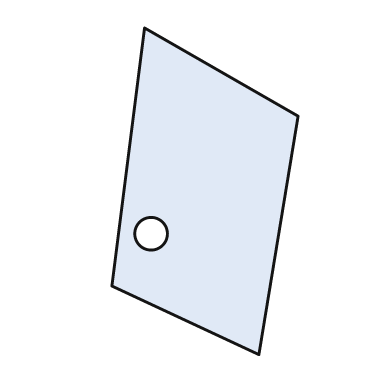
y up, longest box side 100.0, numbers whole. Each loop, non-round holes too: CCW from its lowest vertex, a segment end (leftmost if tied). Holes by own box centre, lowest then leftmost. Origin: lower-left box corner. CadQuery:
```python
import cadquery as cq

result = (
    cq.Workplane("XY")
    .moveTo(45.0, 0.0)
    .lineTo(57.0, 73.0)
    .lineTo(10.0, 100.0)
    .lineTo(0.0, 21.0)
    .close()
    .moveTo(12.0, 37.0)
    .circle(5.0)
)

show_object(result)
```